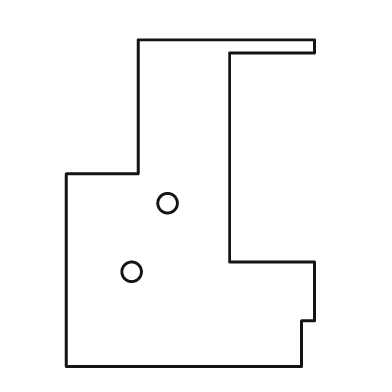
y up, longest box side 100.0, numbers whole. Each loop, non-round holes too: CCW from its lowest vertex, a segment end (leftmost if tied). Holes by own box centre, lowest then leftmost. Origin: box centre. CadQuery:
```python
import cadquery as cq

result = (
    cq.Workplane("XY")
    .moveTo(-38.0, -50.0)
    .lineTo(34.0, -50.0)
    .lineTo(34.0, -36.0)
    .lineTo(38.0, -36.0)
    .lineTo(38.0, -18.0)
    .lineTo(12.0, -18.0)
    .lineTo(12.0, 46.0)
    .lineTo(38.0, 46.0)
    .lineTo(38.0, 50.0)
    .lineTo(-16.0, 50.0)
    .lineTo(-16.0, 9.0)
    .lineTo(-38.0, 9.0)
    .close()
    .moveTo(-18.0, -21.0)
    .circle(3.0)
    .moveTo(-7.0, 0.0)
    .circle(3.0)
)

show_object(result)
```